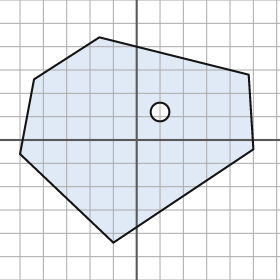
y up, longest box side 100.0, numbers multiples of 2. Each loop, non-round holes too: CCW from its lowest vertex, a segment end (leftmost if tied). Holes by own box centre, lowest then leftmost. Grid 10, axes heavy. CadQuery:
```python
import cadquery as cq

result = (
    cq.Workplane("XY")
    .moveTo(-10.0, -44.0)
    .lineTo(50.0, -4.0)
    .lineTo(48.0, 28.0)
    .lineTo(-16.0, 44.0)
    .lineTo(-44.0, 26.0)
    .lineTo(-50.0, -6.0)
    .close()
    .moveTo(10.0, 12.0)
    .circle(4.0)
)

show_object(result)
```